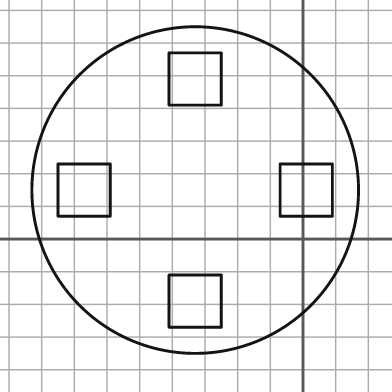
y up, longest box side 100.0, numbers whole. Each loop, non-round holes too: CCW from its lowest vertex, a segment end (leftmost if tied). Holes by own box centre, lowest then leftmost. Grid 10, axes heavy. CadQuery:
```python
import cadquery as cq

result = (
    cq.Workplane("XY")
    .moveTo(-33.0, 15.0)
    .circle(50.0)
    .moveTo(-41.0, -27.0)
    .lineTo(-25.0, -27.0)
    .lineTo(-25.0, -11.0)
    .lineTo(-41.0, -11.0)
    .close()
    .moveTo(-75.0, 7.0)
    .lineTo(-59.0, 7.0)
    .lineTo(-59.0, 23.0)
    .lineTo(-75.0, 23.0)
    .close()
    .moveTo(-7.0, 7.0)
    .lineTo(9.0, 7.0)
    .lineTo(9.0, 23.0)
    .lineTo(-7.0, 23.0)
    .close()
    .moveTo(-41.0, 41.0)
    .lineTo(-25.0, 41.0)
    .lineTo(-25.0, 57.0)
    .lineTo(-41.0, 57.0)
    .close()
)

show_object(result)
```